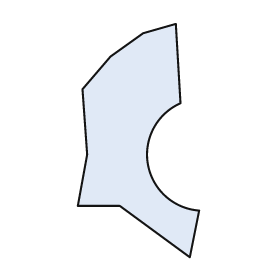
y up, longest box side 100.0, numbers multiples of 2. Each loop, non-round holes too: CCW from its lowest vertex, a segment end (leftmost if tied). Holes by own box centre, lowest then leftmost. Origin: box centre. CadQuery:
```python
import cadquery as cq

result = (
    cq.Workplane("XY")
    .moveTo(22.0, -50.0)
    .lineTo(26.0, -30.0)
    .threePointArc((4.0, -10.0), (18.0, 16.0))
    .lineTo(16.0, 50.0)
    .lineTo(2.0, 46.0)
    .lineTo(-12.0, 36.0)
    .lineTo(-24.0, 22.0)
    .lineTo(-22.0, -6.0)
    .lineTo(-26.0, -28.0)
    .lineTo(-8.0, -28.0)
    .close()
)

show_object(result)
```